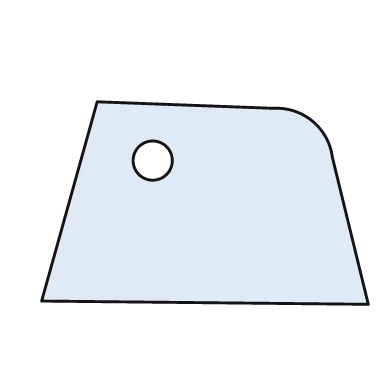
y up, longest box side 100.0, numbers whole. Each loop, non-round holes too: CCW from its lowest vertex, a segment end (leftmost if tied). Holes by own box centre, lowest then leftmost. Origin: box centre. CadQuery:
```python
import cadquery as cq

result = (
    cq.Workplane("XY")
    .moveTo(50.0, -31.0)
    .lineTo(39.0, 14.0)
    .threePointArc((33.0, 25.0), (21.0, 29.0))
    .lineTo(-33.0, 31.0)
    .lineTo(-50.0, -30.0)
    .close()
    .moveTo(-16.0, 13.0)
    .circle(6.0)
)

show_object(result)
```